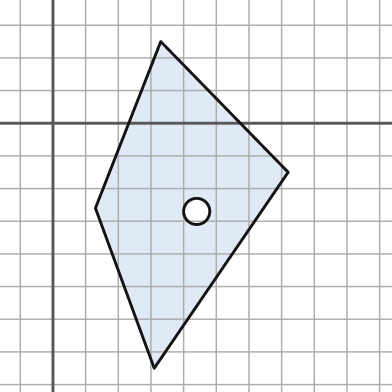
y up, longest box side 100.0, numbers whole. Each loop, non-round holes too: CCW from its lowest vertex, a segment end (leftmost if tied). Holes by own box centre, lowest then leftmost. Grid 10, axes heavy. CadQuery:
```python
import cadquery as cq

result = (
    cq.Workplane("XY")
    .moveTo(31.0, -75.0)
    .lineTo(72.0, -15.0)
    .lineTo(33.0, 25.0)
    .lineTo(13.0, -26.0)
    .close()
    .moveTo(44.0, -27.0)
    .circle(4.0)
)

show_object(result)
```